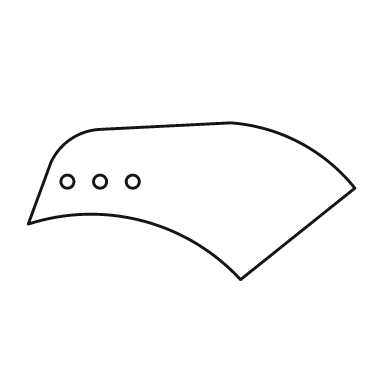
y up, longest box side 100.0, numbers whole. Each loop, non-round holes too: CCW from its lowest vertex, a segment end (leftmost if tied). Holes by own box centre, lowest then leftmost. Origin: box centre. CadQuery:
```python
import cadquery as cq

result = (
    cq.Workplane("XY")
    .moveTo(15.0, -24.0)
    .lineTo(50.0, 4.0)
    .threePointArc((33.0, 18.0), (12.0, 24.0))
    .lineTo(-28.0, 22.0)
    .threePointArc((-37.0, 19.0), (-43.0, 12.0))
    .lineTo(-50.0, -7.0)
    .threePointArc((-15.0, -6.0), (15.0, -24.0))
    .close()
    .moveTo(-38.0, 6.0)
    .circle(2.0)
    .moveTo(-28.0, 6.0)
    .circle(2.0)
    .moveTo(-18.0, 6.0)
    .circle(2.0)
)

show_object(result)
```